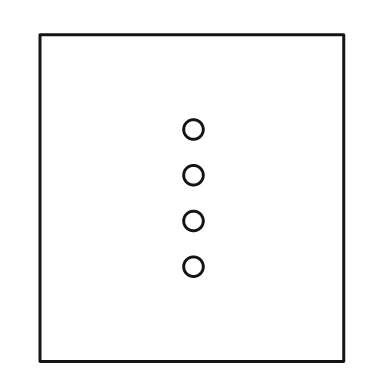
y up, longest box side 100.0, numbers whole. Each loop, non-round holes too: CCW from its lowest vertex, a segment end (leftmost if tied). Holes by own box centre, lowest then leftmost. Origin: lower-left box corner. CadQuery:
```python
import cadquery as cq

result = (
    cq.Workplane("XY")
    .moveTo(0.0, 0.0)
    .lineTo(93.0, 0.0)
    .lineTo(93.0, 100.0)
    .lineTo(0.0, 100.0)
    .close()
    .moveTo(47.0, 29.0)
    .circle(3.0)
    .moveTo(47.0, 43.0)
    .circle(3.0)
    .moveTo(47.0, 57.0)
    .circle(3.0)
    .moveTo(47.0, 71.0)
    .circle(3.0)
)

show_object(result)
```